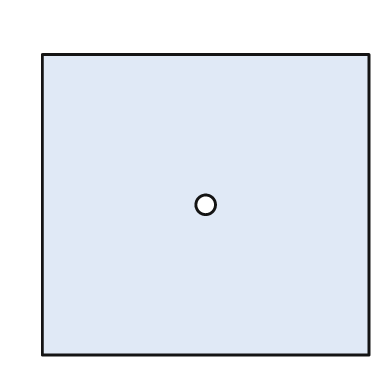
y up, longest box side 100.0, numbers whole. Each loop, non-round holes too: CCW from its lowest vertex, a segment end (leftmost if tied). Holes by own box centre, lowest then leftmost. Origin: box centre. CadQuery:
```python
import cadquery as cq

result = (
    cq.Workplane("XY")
    .moveTo(-50.0, -46.0)
    .lineTo(50.0, -46.0)
    .lineTo(50.0, 46.0)
    .lineTo(-50.0, 46.0)
    .close()
    .moveTo(0.0, 0.0)
    .circle(3.0)
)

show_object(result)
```